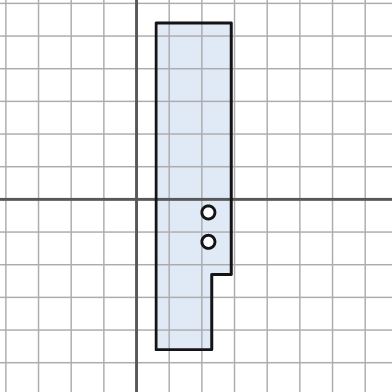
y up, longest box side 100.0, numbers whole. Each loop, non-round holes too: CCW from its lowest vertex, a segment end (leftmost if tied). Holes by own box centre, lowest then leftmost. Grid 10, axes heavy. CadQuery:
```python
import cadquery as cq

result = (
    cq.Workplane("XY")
    .moveTo(6.0, -46.0)
    .lineTo(23.0, -46.0)
    .lineTo(23.0, -23.0)
    .lineTo(29.0, -23.0)
    .lineTo(29.0, 54.0)
    .lineTo(6.0, 54.0)
    .close()
    .moveTo(22.0, -13.0)
    .circle(2.0)
    .moveTo(22.0, -4.0)
    .circle(2.0)
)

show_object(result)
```